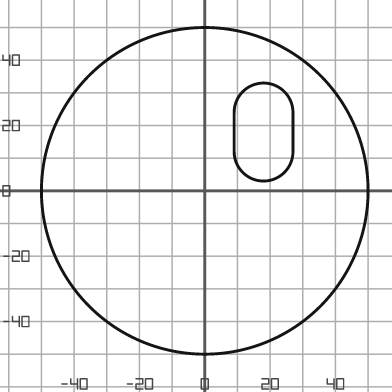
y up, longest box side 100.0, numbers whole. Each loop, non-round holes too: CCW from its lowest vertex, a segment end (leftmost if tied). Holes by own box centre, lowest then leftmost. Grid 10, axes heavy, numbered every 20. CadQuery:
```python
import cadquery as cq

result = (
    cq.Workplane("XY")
    .moveTo(0.0, 0.0)
    .circle(50.0)
    .moveTo(9.0, 12.0)
    .threePointArc((18.0, 3.0), (27.0, 12.0))
    .lineTo(27.0, 24.0)
    .threePointArc((18.0, 33.0), (9.0, 24.0))
    .close()
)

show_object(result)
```